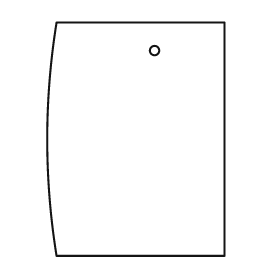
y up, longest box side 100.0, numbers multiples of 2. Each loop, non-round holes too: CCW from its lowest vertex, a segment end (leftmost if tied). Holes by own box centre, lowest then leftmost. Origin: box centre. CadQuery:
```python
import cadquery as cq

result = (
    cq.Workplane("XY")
    .moveTo(-34.0, -50.0)
    .lineTo(38.0, -50.0)
    .lineTo(38.0, 50.0)
    .lineTo(-34.0, 50.0)
    .threePointArc((-38.0, 0.0), (-34.0, -50.0))
    .close()
    .moveTo(8.0, 38.0)
    .circle(2.0)
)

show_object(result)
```